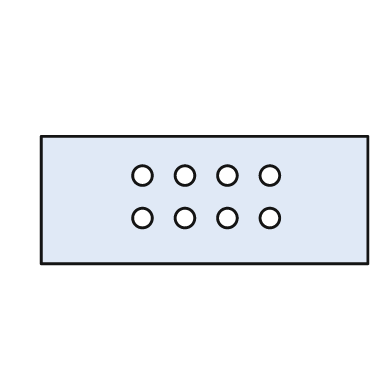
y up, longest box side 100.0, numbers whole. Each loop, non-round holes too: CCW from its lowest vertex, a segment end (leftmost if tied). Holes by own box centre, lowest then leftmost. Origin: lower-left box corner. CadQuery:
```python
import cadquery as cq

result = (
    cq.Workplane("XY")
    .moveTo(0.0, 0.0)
    .lineTo(100.0, 0.0)
    .lineTo(100.0, 39.0)
    .lineTo(0.0, 39.0)
    .close()
    .moveTo(31.0, 14.0)
    .circle(3.0)
    .moveTo(44.0, 14.0)
    .circle(3.0)
    .moveTo(57.0, 14.0)
    .circle(3.0)
    .moveTo(70.0, 14.0)
    .circle(3.0)
    .moveTo(31.0, 27.0)
    .circle(3.0)
    .moveTo(44.0, 27.0)
    .circle(3.0)
    .moveTo(57.0, 27.0)
    .circle(3.0)
    .moveTo(70.0, 27.0)
    .circle(3.0)
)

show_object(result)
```